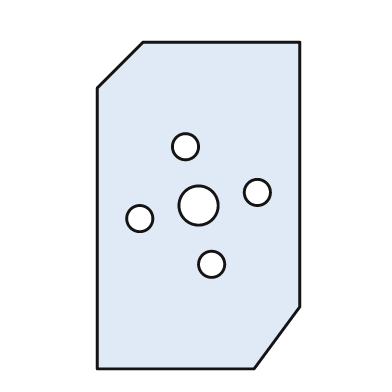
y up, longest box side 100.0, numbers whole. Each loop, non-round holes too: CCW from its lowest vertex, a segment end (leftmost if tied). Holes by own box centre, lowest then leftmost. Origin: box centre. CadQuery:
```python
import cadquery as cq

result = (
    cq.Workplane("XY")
    .moveTo(-31.0, -50.0)
    .lineTo(17.0, -50.0)
    .lineTo(31.0, -31.0)
    .lineTo(31.0, 50.0)
    .lineTo(-17.0, 50.0)
    .lineTo(-31.0, 36.0)
    .close()
    .moveTo(4.0, -18.0)
    .circle(4.0)
    .moveTo(-18.0, -4.0)
    .circle(4.0)
    .moveTo(0.0, 0.0)
    .circle(6.0)
    .moveTo(18.0, 4.0)
    .circle(4.0)
    .moveTo(-4.0, 18.0)
    .circle(4.0)
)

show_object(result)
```